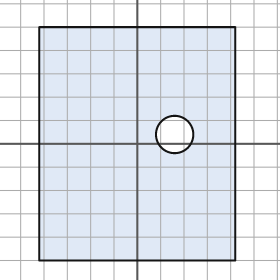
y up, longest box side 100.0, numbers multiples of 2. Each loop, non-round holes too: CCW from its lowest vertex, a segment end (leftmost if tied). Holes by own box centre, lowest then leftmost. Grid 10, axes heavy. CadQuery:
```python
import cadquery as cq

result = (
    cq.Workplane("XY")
    .moveTo(-42.0, -50.0)
    .lineTo(42.0, -50.0)
    .lineTo(42.0, 50.0)
    .lineTo(-42.0, 50.0)
    .close()
    .moveTo(16.0, 4.0)
    .circle(8.0)
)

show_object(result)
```